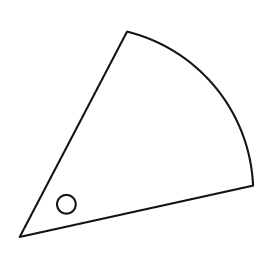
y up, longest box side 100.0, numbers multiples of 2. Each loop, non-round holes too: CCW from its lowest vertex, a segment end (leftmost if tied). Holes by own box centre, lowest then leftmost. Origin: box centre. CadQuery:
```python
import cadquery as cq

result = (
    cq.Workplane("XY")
    .moveTo(-50.0, -44.0)
    .lineTo(50.0, -22.0)
    .threePointArc((34.0, 20.0), (-4.0, 44.0))
    .close()
    .moveTo(-30.0, -30.0)
    .circle(4.0)
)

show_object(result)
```